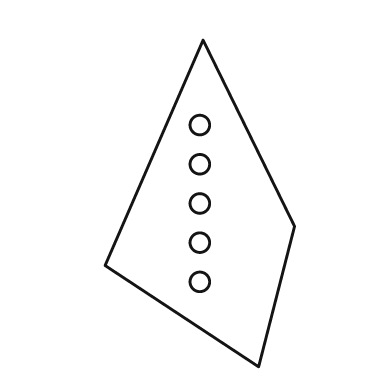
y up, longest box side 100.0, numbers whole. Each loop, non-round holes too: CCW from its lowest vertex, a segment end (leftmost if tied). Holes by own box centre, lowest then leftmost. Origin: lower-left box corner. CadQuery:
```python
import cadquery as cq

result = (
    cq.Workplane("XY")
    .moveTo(47.0, 0.0)
    .lineTo(58.0, 43.0)
    .lineTo(30.0, 100.0)
    .lineTo(0.0, 31.0)
    .close()
    .moveTo(29.0, 26.0)
    .circle(3.0)
    .moveTo(29.0, 38.0)
    .circle(3.0)
    .moveTo(29.0, 50.0)
    .circle(3.0)
    .moveTo(29.0, 62.0)
    .circle(3.0)
    .moveTo(29.0, 74.0)
    .circle(3.0)
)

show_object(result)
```